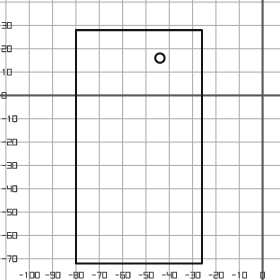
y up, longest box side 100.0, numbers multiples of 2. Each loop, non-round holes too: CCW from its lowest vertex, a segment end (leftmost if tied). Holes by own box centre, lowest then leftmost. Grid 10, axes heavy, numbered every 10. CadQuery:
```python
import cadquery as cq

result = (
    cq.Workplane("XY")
    .moveTo(-80.0, -72.0)
    .lineTo(-26.0, -72.0)
    .lineTo(-26.0, 28.0)
    .lineTo(-80.0, 28.0)
    .close()
    .moveTo(-44.0, 16.0)
    .circle(2.0)
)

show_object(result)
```